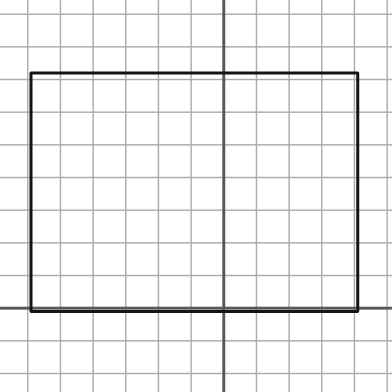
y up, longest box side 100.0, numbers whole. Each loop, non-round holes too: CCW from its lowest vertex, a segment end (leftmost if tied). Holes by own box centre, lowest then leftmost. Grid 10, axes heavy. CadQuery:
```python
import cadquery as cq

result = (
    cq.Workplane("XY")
    .moveTo(-59.0, -1.0)
    .lineTo(41.0, -1.0)
    .lineTo(41.0, 72.0)
    .lineTo(-59.0, 72.0)
    .close()
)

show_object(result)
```